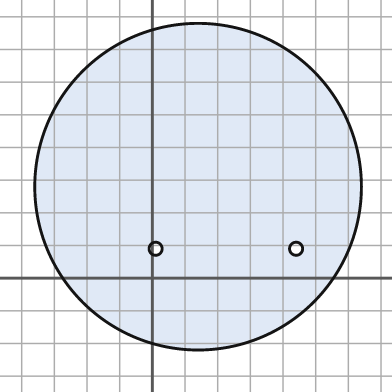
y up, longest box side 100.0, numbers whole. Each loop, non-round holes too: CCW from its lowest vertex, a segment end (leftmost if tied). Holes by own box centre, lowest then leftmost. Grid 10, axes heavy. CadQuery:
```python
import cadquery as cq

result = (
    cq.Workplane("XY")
    .moveTo(14.0, 28.0)
    .circle(50.0)
    .moveTo(1.0, 9.0)
    .circle(2.0)
    .moveTo(44.0, 9.0)
    .circle(2.0)
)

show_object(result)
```